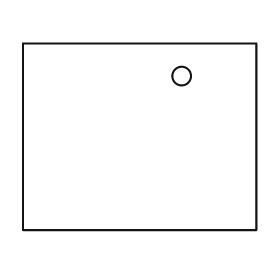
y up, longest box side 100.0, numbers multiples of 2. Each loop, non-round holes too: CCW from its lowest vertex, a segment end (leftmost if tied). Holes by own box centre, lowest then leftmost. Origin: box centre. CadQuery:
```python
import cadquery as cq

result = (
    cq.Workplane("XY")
    .moveTo(-50.0, -40.0)
    .lineTo(50.0, -40.0)
    .lineTo(50.0, 40.0)
    .lineTo(-50.0, 40.0)
    .close()
    .moveTo(18.0, 26.0)
    .circle(4.0)
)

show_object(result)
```